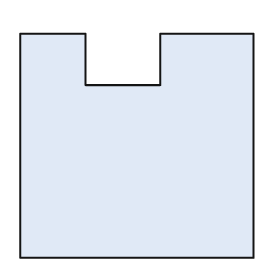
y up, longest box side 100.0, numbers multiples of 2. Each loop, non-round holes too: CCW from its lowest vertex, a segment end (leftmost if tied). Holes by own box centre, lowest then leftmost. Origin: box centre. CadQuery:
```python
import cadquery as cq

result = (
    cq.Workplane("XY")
    .moveTo(-50.0, -48.0)
    .lineTo(50.0, -48.0)
    .lineTo(50.0, 48.0)
    .lineTo(10.0, 48.0)
    .lineTo(10.0, 26.0)
    .lineTo(-22.0, 26.0)
    .lineTo(-22.0, 48.0)
    .lineTo(-50.0, 48.0)
    .close()
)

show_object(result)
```